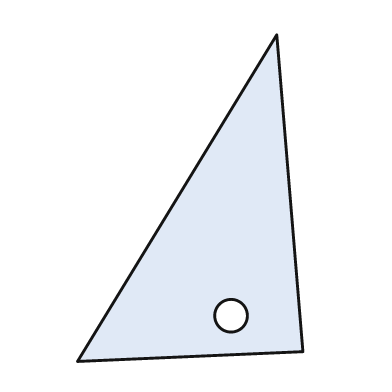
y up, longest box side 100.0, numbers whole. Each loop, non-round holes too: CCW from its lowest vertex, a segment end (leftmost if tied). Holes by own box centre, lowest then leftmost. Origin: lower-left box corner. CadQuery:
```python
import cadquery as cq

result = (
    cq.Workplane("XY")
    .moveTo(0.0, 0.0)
    .lineTo(69.0, 3.0)
    .lineTo(61.0, 100.0)
    .close()
    .moveTo(47.0, 14.0)
    .circle(5.0)
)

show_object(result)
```